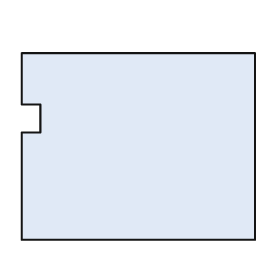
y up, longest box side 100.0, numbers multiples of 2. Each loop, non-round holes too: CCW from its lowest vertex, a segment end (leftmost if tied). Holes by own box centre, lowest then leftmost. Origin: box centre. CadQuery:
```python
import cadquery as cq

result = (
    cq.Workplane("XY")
    .moveTo(-50.0, -40.0)
    .lineTo(50.0, -40.0)
    .lineTo(50.0, 40.0)
    .lineTo(-50.0, 40.0)
    .lineTo(-50.0, 18.0)
    .lineTo(-42.0, 18.0)
    .lineTo(-42.0, 6.0)
    .lineTo(-50.0, 6.0)
    .close()
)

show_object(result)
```